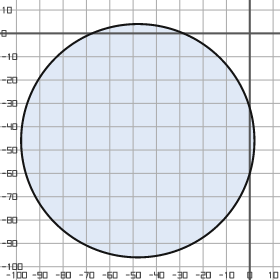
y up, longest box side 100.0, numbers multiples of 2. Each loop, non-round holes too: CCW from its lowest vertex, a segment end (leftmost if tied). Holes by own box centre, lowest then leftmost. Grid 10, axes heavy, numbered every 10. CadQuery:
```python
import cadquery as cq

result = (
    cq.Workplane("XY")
    .moveTo(-48.0, -46.0)
    .circle(50.0)
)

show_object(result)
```